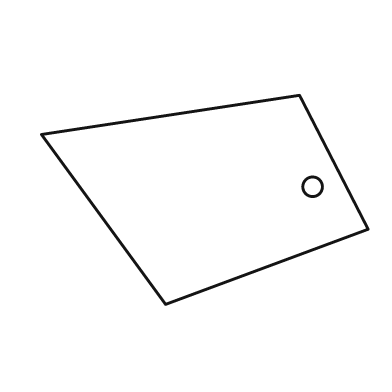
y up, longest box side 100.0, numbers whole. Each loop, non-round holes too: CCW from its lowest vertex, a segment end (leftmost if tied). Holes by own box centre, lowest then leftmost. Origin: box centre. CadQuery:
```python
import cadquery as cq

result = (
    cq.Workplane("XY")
    .moveTo(-12.0, -32.0)
    .lineTo(50.0, -9.0)
    .lineTo(29.0, 32.0)
    .lineTo(-50.0, 20.0)
    .close()
    .moveTo(33.0, 4.0)
    .circle(3.0)
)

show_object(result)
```